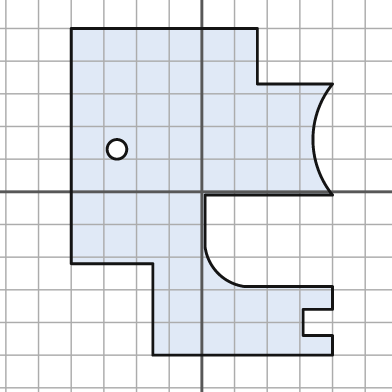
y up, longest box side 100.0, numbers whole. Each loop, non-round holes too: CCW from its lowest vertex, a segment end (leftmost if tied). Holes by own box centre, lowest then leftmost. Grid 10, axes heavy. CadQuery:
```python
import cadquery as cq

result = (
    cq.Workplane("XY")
    .moveTo(-15.0, -50.0)
    .lineTo(40.0, -50.0)
    .lineTo(40.0, -44.0)
    .lineTo(31.0, -44.0)
    .lineTo(31.0, -36.0)
    .lineTo(40.0, -36.0)
    .lineTo(40.0, -29.0)
    .lineTo(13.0, -29.0)
    .threePointArc((5.0, -25.0), (1.0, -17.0))
    .lineTo(1.0, -1.0)
    .lineTo(40.0, -1.0)
    .threePointArc((34.0, 16.0), (40.0, 33.0))
    .lineTo(17.0, 33.0)
    .lineTo(17.0, 50.0)
    .lineTo(-40.0, 50.0)
    .lineTo(-40.0, -22.0)
    .lineTo(-15.0, -22.0)
    .close()
    .moveTo(-26.0, 13.0)
    .circle(3.0)
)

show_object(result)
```